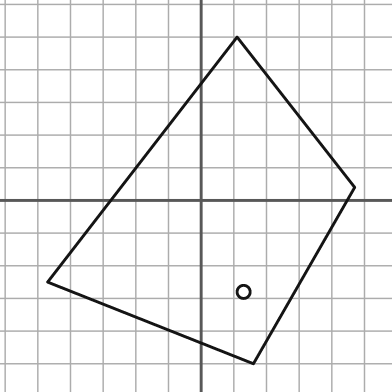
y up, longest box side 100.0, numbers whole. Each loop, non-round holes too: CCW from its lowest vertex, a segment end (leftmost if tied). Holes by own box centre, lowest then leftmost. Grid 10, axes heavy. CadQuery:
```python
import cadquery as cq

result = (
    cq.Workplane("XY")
    .moveTo(16.0, -50.0)
    .lineTo(47.0, 4.0)
    .lineTo(11.0, 50.0)
    .lineTo(-47.0, -25.0)
    .close()
    .moveTo(13.0, -28.0)
    .circle(2.0)
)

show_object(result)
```